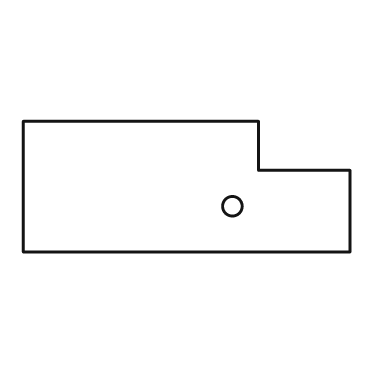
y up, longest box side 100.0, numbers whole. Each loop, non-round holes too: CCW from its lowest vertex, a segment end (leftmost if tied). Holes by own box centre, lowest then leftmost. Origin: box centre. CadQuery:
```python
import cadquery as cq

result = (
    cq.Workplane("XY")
    .moveTo(-50.0, -20.0)
    .lineTo(50.0, -20.0)
    .lineTo(50.0, 5.0)
    .lineTo(22.0, 5.0)
    .lineTo(22.0, 20.0)
    .lineTo(-50.0, 20.0)
    .close()
    .moveTo(14.0, -6.0)
    .circle(3.0)
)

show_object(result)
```